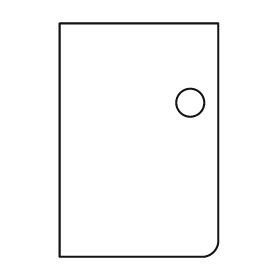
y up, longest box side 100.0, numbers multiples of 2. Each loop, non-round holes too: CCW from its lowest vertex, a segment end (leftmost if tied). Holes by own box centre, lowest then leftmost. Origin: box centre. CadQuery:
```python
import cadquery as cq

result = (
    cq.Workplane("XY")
    .moveTo(-34.0, -50.0)
    .lineTo(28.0, -50.0)
    .threePointArc((32.0, -48.0), (34.0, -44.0))
    .lineTo(34.0, 50.0)
    .lineTo(-34.0, 50.0)
    .close()
    .moveTo(22.0, 16.0)
    .circle(6.0)
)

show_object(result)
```